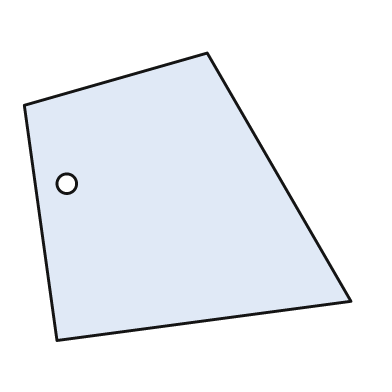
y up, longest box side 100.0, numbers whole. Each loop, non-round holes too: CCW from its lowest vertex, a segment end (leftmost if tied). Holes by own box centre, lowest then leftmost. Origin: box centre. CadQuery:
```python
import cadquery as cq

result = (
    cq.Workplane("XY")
    .moveTo(-40.0, -44.0)
    .lineTo(50.0, -32.0)
    .lineTo(6.0, 44.0)
    .lineTo(-50.0, 28.0)
    .close()
    .moveTo(-37.0, 4.0)
    .circle(3.0)
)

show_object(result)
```